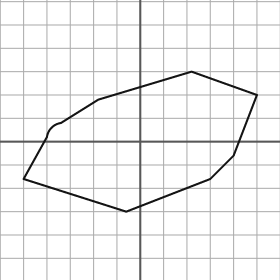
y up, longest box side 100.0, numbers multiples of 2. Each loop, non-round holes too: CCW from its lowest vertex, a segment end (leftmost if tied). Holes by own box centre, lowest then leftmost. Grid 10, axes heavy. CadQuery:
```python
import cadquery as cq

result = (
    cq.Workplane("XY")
    .moveTo(-6.0, -30.0)
    .lineTo(30.0, -16.0)
    .lineTo(40.0, -6.0)
    .lineTo(50.0, 20.0)
    .lineTo(22.0, 30.0)
    .lineTo(-18.0, 18.0)
    .lineTo(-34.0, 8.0)
    .threePointArc((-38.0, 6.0), (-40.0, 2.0))
    .lineTo(-50.0, -16.0)
    .close()
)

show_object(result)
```